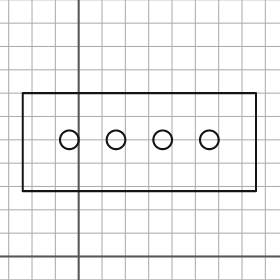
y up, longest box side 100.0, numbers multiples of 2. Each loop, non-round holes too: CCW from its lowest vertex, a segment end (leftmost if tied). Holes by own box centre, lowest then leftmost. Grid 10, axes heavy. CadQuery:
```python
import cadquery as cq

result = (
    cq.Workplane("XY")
    .moveTo(-24.0, 28.0)
    .lineTo(76.0, 28.0)
    .lineTo(76.0, 70.0)
    .lineTo(-24.0, 70.0)
    .close()
    .moveTo(-4.0, 50.0)
    .circle(4.0)
    .moveTo(16.0, 50.0)
    .circle(4.0)
    .moveTo(36.0, 50.0)
    .circle(4.0)
    .moveTo(56.0, 50.0)
    .circle(4.0)
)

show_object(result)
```